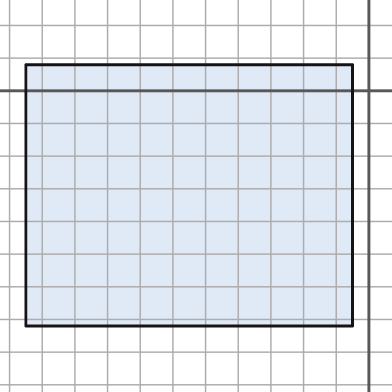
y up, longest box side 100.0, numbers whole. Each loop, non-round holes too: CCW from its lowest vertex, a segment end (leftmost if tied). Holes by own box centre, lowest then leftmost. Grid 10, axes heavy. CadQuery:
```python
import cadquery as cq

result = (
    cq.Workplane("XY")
    .moveTo(-105.0, -72.0)
    .lineTo(-5.0, -72.0)
    .lineTo(-5.0, 8.0)
    .lineTo(-105.0, 8.0)
    .close()
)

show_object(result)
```